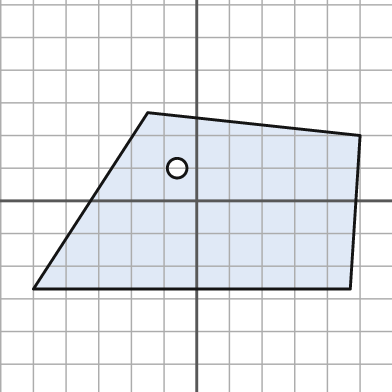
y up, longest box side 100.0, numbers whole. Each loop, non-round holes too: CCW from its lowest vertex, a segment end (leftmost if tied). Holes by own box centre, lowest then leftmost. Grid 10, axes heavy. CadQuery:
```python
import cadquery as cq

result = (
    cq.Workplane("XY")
    .moveTo(-50.0, -27.0)
    .lineTo(47.0, -27.0)
    .lineTo(50.0, 20.0)
    .lineTo(-15.0, 27.0)
    .close()
    .moveTo(-6.0, 10.0)
    .circle(3.0)
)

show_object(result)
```